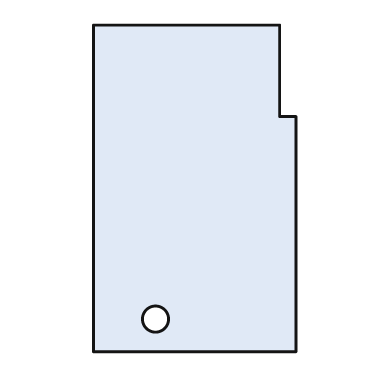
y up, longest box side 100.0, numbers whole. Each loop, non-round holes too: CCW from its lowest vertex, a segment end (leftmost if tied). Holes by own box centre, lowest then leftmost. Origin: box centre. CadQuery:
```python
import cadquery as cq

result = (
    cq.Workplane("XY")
    .moveTo(-31.0, -50.0)
    .lineTo(31.0, -50.0)
    .lineTo(31.0, 22.0)
    .lineTo(26.0, 22.0)
    .lineTo(26.0, 50.0)
    .lineTo(-31.0, 50.0)
    .close()
    .moveTo(-12.0, -40.0)
    .circle(4.0)
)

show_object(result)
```